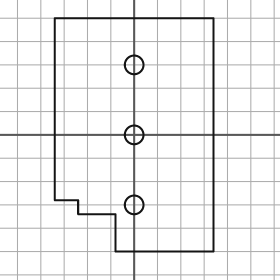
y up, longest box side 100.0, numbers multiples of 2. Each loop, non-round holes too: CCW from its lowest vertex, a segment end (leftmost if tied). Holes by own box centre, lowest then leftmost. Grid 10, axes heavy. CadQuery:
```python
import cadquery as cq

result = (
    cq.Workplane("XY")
    .moveTo(-8.0, -50.0)
    .lineTo(34.0, -50.0)
    .lineTo(34.0, 50.0)
    .lineTo(-34.0, 50.0)
    .lineTo(-34.0, -28.0)
    .lineTo(-24.0, -28.0)
    .lineTo(-24.0, -34.0)
    .lineTo(-8.0, -34.0)
    .close()
    .moveTo(0.0, -30.0)
    .circle(4.0)
    .moveTo(0.0, 0.0)
    .circle(4.0)
    .moveTo(0.0, 30.0)
    .circle(4.0)
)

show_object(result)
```